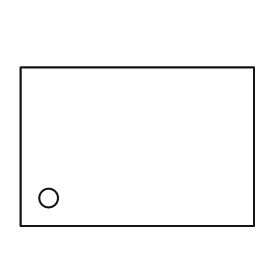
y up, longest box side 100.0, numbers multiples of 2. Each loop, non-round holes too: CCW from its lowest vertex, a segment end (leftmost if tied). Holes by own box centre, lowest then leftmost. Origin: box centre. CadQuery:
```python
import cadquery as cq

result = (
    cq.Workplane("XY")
    .moveTo(-50.0, -34.0)
    .lineTo(50.0, -34.0)
    .lineTo(50.0, 34.0)
    .lineTo(-50.0, 34.0)
    .close()
    .moveTo(-38.0, -22.0)
    .circle(4.0)
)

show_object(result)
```